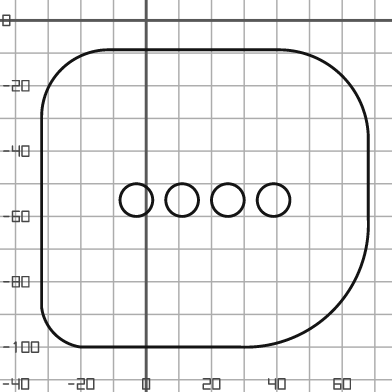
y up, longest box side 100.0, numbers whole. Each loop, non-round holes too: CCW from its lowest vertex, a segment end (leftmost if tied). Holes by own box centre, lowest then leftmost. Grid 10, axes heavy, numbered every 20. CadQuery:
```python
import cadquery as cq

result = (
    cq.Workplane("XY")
    .moveTo(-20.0, -100.0)
    .lineTo(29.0, -100.0)
    .threePointArc((57.0, -89.0), (68.0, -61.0))
    .lineTo(68.0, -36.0)
    .threePointArc((60.0, -17.0), (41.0, -9.0))
    .lineTo(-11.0, -9.0)
    .threePointArc((-26.0, -15.0), (-32.0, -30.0))
    .lineTo(-32.0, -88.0)
    .threePointArc((-28.0, -96.0), (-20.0, -100.0))
    .close()
    .moveTo(-3.0, -55.0)
    .circle(5.0)
    .moveTo(11.0, -55.0)
    .circle(5.0)
    .moveTo(25.0, -55.0)
    .circle(5.0)
    .moveTo(39.0, -55.0)
    .circle(5.0)
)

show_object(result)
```